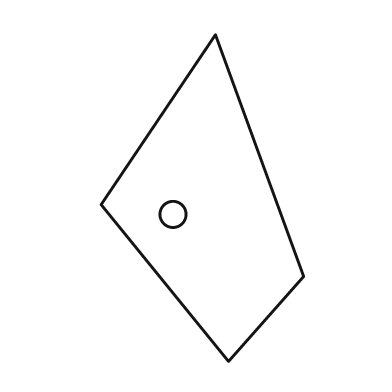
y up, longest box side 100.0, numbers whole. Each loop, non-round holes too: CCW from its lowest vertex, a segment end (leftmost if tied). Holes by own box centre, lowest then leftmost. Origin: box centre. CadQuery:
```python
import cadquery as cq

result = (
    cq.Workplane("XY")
    .moveTo(8.0, -50.0)
    .lineTo(31.0, -24.0)
    .lineTo(4.0, 50.0)
    .lineTo(-31.0, -2.0)
    .close()
    .moveTo(-9.0, -5.0)
    .circle(4.0)
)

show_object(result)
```